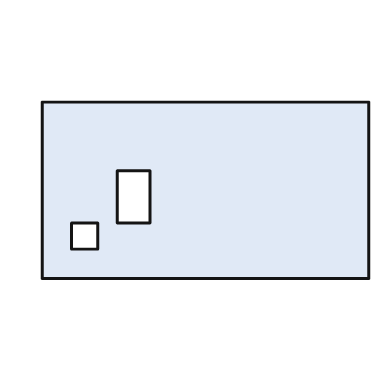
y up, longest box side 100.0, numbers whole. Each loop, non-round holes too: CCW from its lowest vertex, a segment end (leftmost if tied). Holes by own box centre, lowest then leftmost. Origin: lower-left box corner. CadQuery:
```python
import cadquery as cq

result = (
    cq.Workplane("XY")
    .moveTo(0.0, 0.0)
    .lineTo(100.0, 0.0)
    .lineTo(100.0, 54.0)
    .lineTo(0.0, 54.0)
    .close()
    .moveTo(9.0, 9.0)
    .lineTo(17.0, 9.0)
    .lineTo(17.0, 17.0)
    .lineTo(9.0, 17.0)
    .close()
    .moveTo(23.0, 17.0)
    .lineTo(33.0, 17.0)
    .lineTo(33.0, 33.0)
    .lineTo(23.0, 33.0)
    .close()
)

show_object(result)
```